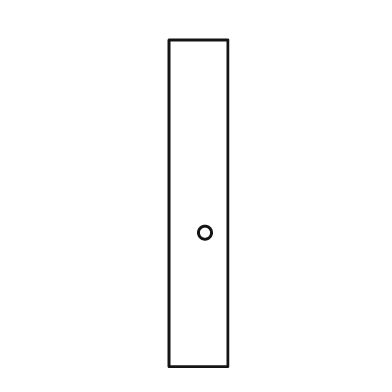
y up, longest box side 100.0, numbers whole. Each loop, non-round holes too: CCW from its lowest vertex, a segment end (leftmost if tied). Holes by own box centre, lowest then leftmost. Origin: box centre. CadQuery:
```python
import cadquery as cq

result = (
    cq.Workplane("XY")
    .moveTo(-9.0, -50.0)
    .lineTo(9.0, -50.0)
    .lineTo(9.0, 50.0)
    .lineTo(-9.0, 50.0)
    .close()
    .moveTo(2.0, -9.0)
    .circle(2.0)
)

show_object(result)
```